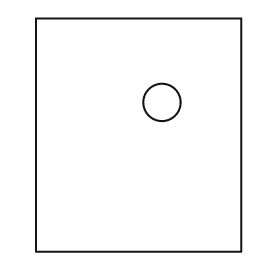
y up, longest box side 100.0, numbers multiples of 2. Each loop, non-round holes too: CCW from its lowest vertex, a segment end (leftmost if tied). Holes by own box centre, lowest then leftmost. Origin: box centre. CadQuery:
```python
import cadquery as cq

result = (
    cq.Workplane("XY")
    .moveTo(-44.0, -50.0)
    .lineTo(44.0, -50.0)
    .lineTo(44.0, 50.0)
    .lineTo(-44.0, 50.0)
    .close()
    .moveTo(10.0, 14.0)
    .circle(8.0)
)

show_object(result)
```